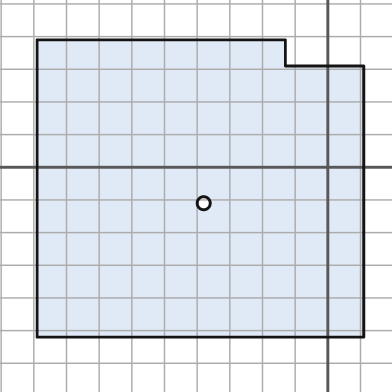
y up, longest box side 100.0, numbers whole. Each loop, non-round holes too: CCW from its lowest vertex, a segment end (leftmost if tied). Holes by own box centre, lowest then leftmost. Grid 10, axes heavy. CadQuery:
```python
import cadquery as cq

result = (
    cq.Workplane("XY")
    .moveTo(-89.0, -52.0)
    .lineTo(11.0, -52.0)
    .lineTo(11.0, 31.0)
    .lineTo(-13.0, 31.0)
    .lineTo(-13.0, 39.0)
    .lineTo(-89.0, 39.0)
    .close()
    .moveTo(-38.0, -11.0)
    .circle(2.0)
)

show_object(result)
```